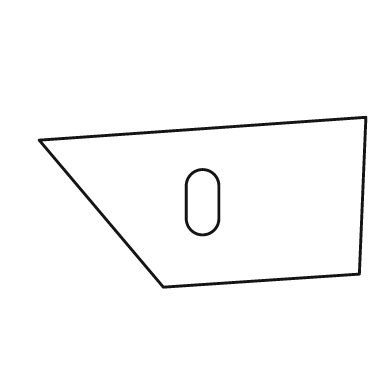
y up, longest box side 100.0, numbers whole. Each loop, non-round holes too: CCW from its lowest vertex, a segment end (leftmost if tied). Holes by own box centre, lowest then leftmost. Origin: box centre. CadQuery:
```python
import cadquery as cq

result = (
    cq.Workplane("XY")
    .moveTo(-12.0, -26.0)
    .lineTo(48.0, -22.0)
    .lineTo(50.0, 26.0)
    .lineTo(-50.0, 19.0)
    .close()
    .moveTo(-5.0, -5.0)
    .threePointArc((0.0, -10.0), (5.0, -5.0))
    .lineTo(5.0, 5.0)
    .threePointArc((0.0, 10.0), (-5.0, 5.0))
    .close()
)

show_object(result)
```